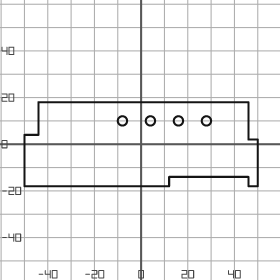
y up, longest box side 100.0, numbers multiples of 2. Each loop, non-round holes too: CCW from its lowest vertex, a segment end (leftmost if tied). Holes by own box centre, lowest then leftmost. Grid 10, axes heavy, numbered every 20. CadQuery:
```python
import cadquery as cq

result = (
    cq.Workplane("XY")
    .moveTo(-50.0, -18.0)
    .lineTo(12.0, -18.0)
    .lineTo(12.0, -14.0)
    .lineTo(46.0, -14.0)
    .lineTo(46.0, -18.0)
    .lineTo(50.0, -18.0)
    .lineTo(50.0, 2.0)
    .lineTo(46.0, 2.0)
    .lineTo(46.0, 18.0)
    .lineTo(-44.0, 18.0)
    .lineTo(-44.0, 4.0)
    .lineTo(-50.0, 4.0)
    .close()
    .moveTo(-8.0, 10.0)
    .circle(2.0)
    .moveTo(4.0, 10.0)
    .circle(2.0)
    .moveTo(16.0, 10.0)
    .circle(2.0)
    .moveTo(28.0, 10.0)
    .circle(2.0)
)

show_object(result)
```